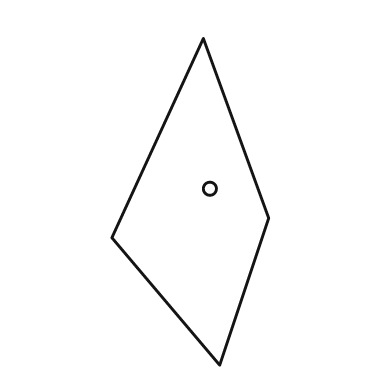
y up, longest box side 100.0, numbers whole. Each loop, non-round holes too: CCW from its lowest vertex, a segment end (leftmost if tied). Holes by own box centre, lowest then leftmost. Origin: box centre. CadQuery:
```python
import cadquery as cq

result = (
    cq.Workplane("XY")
    .moveTo(9.0, -50.0)
    .lineTo(24.0, -5.0)
    .lineTo(4.0, 50.0)
    .lineTo(-24.0, -11.0)
    .close()
    .moveTo(6.0, 4.0)
    .circle(2.0)
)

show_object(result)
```